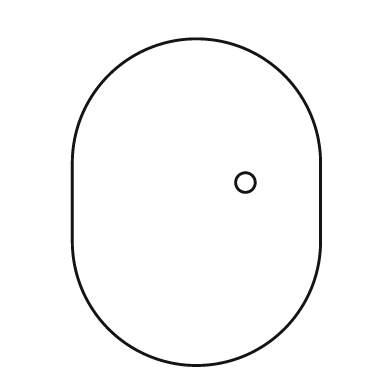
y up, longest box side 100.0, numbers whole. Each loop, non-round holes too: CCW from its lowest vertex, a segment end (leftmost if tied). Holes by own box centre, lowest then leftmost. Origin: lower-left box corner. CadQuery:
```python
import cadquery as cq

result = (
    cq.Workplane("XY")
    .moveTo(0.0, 38.0)
    .threePointArc((38.0, 0.0), (76.0, 38.0))
    .lineTo(76.0, 62.0)
    .threePointArc((38.0, 100.0), (0.0, 62.0))
    .close()
    .moveTo(53.0, 56.0)
    .circle(3.0)
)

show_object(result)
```